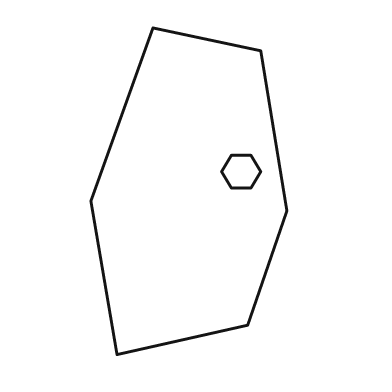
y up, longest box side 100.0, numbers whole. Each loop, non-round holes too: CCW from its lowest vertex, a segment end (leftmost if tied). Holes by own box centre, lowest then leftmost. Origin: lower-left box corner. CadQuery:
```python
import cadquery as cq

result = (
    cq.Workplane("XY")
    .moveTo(8.0, 0.0)
    .lineTo(48.0, 9.0)
    .lineTo(60.0, 44.0)
    .lineTo(52.0, 93.0)
    .lineTo(19.0, 100.0)
    .lineTo(0.0, 47.0)
    .close()
    .moveTo(43.0, 51.0)
    .lineTo(49.0, 51.0)
    .lineTo(52.0, 56.0)
    .lineTo(49.0, 61.0)
    .lineTo(43.0, 61.0)
    .lineTo(40.0, 56.0)
    .close()
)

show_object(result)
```